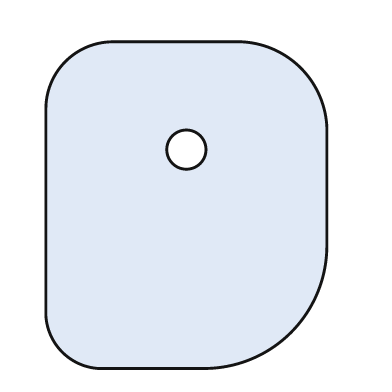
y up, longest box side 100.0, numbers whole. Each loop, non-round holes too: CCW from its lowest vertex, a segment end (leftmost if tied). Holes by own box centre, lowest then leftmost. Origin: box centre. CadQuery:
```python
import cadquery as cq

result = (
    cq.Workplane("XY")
    .moveTo(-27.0, -50.0)
    .lineTo(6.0, -50.0)
    .threePointArc((32.0, -39.0), (43.0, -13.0))
    .lineTo(43.0, 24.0)
    .threePointArc((35.0, 42.0), (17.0, 50.0))
    .lineTo(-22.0, 50.0)
    .threePointArc((-37.0, 44.0), (-43.0, 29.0))
    .lineTo(-43.0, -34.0)
    .threePointArc((-38.0, -45.0), (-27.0, -50.0))
    .close()
    .moveTo(0.0, 17.0)
    .circle(6.0)
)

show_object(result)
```